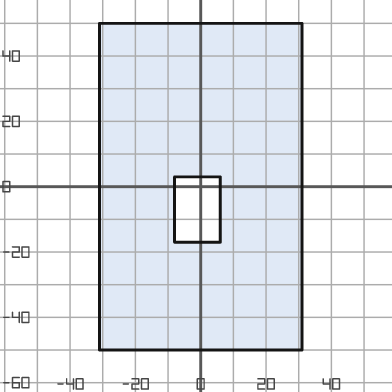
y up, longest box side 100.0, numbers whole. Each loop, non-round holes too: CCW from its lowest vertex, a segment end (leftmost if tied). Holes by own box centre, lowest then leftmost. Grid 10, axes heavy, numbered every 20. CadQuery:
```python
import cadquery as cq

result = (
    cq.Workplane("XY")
    .moveTo(-31.0, -50.0)
    .lineTo(31.0, -50.0)
    .lineTo(31.0, 50.0)
    .lineTo(-31.0, 50.0)
    .close()
    .moveTo(-8.0, -17.0)
    .lineTo(6.0, -17.0)
    .lineTo(6.0, 3.0)
    .lineTo(-8.0, 3.0)
    .close()
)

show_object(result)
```